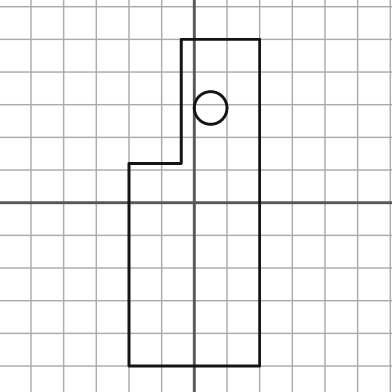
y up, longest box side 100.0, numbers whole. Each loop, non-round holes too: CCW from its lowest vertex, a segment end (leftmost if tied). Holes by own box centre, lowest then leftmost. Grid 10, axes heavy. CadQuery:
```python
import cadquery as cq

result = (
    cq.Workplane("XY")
    .moveTo(-20.0, -50.0)
    .lineTo(20.0, -50.0)
    .lineTo(20.0, 50.0)
    .lineTo(-4.0, 50.0)
    .lineTo(-4.0, 12.0)
    .lineTo(-20.0, 12.0)
    .close()
    .moveTo(5.0, 29.0)
    .circle(5.0)
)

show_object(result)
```